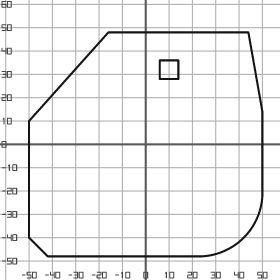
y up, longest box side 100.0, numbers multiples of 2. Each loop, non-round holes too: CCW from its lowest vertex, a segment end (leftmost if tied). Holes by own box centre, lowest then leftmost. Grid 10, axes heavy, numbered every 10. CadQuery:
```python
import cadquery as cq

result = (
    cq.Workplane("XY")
    .moveTo(-42.0, -48.0)
    .lineTo(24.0, -48.0)
    .threePointArc((42.0, -40.0), (50.0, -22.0))
    .lineTo(50.0, 14.0)
    .lineTo(44.0, 48.0)
    .lineTo(-16.0, 48.0)
    .lineTo(-50.0, 10.0)
    .lineTo(-50.0, -40.0)
    .close()
    .moveTo(6.0, 28.0)
    .lineTo(14.0, 28.0)
    .lineTo(14.0, 36.0)
    .lineTo(6.0, 36.0)
    .close()
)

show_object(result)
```